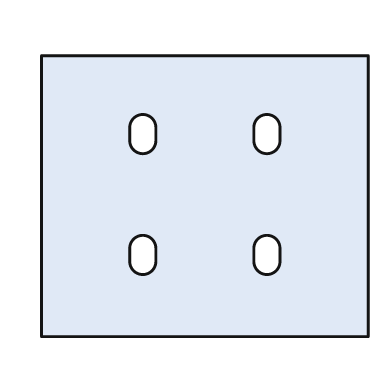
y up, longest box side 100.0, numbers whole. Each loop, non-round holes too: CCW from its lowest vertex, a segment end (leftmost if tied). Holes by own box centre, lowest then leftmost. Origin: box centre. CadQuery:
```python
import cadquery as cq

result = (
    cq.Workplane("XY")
    .moveTo(-50.0, -43.0)
    .lineTo(50.0, -43.0)
    .lineTo(50.0, 43.0)
    .lineTo(-50.0, 43.0)
    .close()
    .moveTo(-23.0, -20.0)
    .threePointArc((-19.0, -24.0), (-15.0, -20.0))
    .lineTo(-15.0, -16.0)
    .threePointArc((-19.0, -12.0), (-23.0, -16.0))
    .close()
    .moveTo(15.0, -20.0)
    .threePointArc((19.0, -24.0), (23.0, -20.0))
    .lineTo(23.0, -16.0)
    .threePointArc((19.0, -12.0), (15.0, -16.0))
    .close()
    .moveTo(-23.0, 17.0)
    .threePointArc((-19.0, 13.0), (-15.0, 17.0))
    .lineTo(-15.0, 21.0)
    .threePointArc((-19.0, 25.0), (-23.0, 21.0))
    .close()
    .moveTo(15.0, 17.0)
    .threePointArc((19.0, 13.0), (23.0, 17.0))
    .lineTo(23.0, 21.0)
    .threePointArc((19.0, 25.0), (15.0, 21.0))
    .close()
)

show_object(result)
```